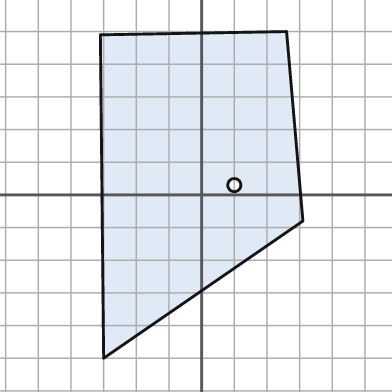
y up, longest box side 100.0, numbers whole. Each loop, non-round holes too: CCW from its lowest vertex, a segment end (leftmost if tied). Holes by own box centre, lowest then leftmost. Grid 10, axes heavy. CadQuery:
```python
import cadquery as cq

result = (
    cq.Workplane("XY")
    .moveTo(-30.0, -50.0)
    .lineTo(31.0, -8.0)
    .lineTo(26.0, 50.0)
    .lineTo(-31.0, 49.0)
    .close()
    .moveTo(10.0, 3.0)
    .circle(2.0)
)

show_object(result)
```